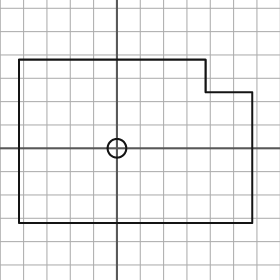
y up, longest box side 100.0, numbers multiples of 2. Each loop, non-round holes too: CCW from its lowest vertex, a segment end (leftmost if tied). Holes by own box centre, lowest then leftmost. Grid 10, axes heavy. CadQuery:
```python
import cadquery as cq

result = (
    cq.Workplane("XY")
    .moveTo(-42.0, -32.0)
    .lineTo(58.0, -32.0)
    .lineTo(58.0, 24.0)
    .lineTo(38.0, 24.0)
    .lineTo(38.0, 38.0)
    .lineTo(-42.0, 38.0)
    .close()
    .moveTo(0.0, 0.0)
    .circle(4.0)
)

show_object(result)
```